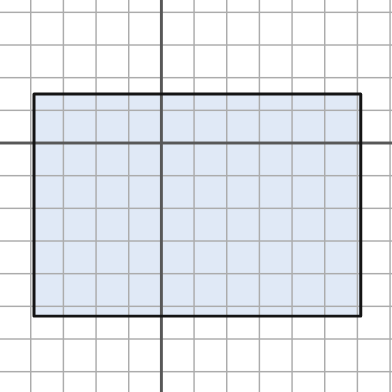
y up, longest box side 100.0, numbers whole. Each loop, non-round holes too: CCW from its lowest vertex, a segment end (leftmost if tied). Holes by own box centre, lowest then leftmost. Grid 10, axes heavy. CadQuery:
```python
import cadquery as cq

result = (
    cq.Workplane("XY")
    .moveTo(-39.0, -53.0)
    .lineTo(61.0, -53.0)
    .lineTo(61.0, 15.0)
    .lineTo(-39.0, 15.0)
    .close()
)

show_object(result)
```